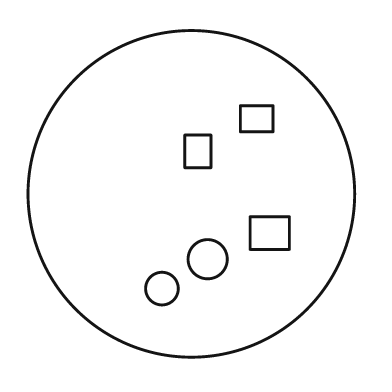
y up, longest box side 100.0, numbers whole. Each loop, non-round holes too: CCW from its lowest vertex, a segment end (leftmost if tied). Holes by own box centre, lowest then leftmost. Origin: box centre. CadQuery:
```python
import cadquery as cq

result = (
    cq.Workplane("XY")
    .moveTo(0.0, 0.0)
    .circle(50.0)
    .moveTo(-9.0, -29.0)
    .circle(5.0)
    .moveTo(5.0, -20.0)
    .circle(6.0)
    .moveTo(18.0, -17.0)
    .lineTo(30.0, -17.0)
    .lineTo(30.0, -7.0)
    .lineTo(18.0, -7.0)
    .close()
    .moveTo(-2.0, 8.0)
    .lineTo(6.0, 8.0)
    .lineTo(6.0, 18.0)
    .lineTo(-2.0, 18.0)
    .close()
    .moveTo(15.0, 19.0)
    .lineTo(25.0, 19.0)
    .lineTo(25.0, 27.0)
    .lineTo(15.0, 27.0)
    .close()
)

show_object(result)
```